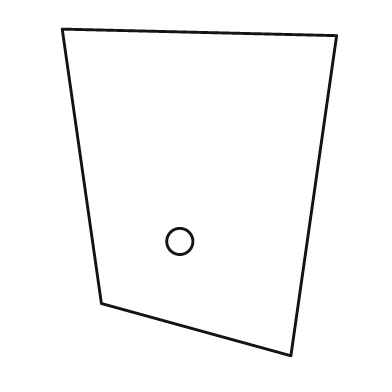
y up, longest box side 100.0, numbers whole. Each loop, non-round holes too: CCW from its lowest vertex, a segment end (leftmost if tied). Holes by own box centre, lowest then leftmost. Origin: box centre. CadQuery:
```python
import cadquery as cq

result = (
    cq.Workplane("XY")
    .moveTo(28.0, -50.0)
    .lineTo(42.0, 48.0)
    .lineTo(-42.0, 50.0)
    .lineTo(-30.0, -34.0)
    .close()
    .moveTo(-6.0, -15.0)
    .circle(4.0)
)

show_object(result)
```